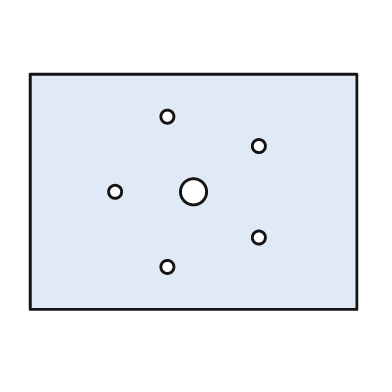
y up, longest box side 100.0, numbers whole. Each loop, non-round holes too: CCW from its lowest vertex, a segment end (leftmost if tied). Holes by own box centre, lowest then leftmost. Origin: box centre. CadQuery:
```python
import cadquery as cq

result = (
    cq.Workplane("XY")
    .moveTo(-50.0, -36.0)
    .lineTo(50.0, -36.0)
    .lineTo(50.0, 36.0)
    .lineTo(-50.0, 36.0)
    .close()
    .moveTo(-8.0, -23.0)
    .circle(2.0)
    .moveTo(20.0, -14.0)
    .circle(2.0)
    .moveTo(-24.0, 0.0)
    .circle(2.0)
    .moveTo(0.0, 0.0)
    .circle(4.0)
    .moveTo(20.0, 14.0)
    .circle(2.0)
    .moveTo(-8.0, 23.0)
    .circle(2.0)
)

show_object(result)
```